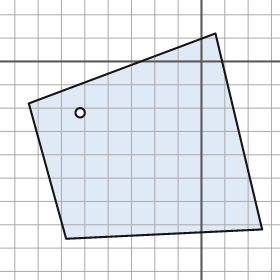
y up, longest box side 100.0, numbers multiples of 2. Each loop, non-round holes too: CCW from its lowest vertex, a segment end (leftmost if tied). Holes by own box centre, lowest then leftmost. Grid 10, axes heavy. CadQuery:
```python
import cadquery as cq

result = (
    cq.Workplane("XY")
    .moveTo(-58.0, -76.0)
    .lineTo(26.0, -72.0)
    .lineTo(6.0, 12.0)
    .lineTo(-74.0, -18.0)
    .close()
    .moveTo(-52.0, -22.0)
    .circle(2.0)
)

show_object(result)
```